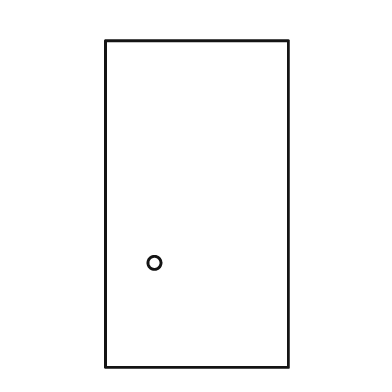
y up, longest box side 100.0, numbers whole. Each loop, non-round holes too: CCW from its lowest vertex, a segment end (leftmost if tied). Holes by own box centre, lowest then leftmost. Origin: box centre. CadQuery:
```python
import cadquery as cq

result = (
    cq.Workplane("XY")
    .moveTo(-28.0, -50.0)
    .lineTo(28.0, -50.0)
    .lineTo(28.0, 50.0)
    .lineTo(-28.0, 50.0)
    .close()
    .moveTo(-13.0, -18.0)
    .circle(2.0)
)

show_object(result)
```